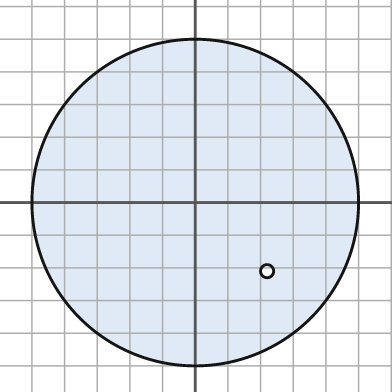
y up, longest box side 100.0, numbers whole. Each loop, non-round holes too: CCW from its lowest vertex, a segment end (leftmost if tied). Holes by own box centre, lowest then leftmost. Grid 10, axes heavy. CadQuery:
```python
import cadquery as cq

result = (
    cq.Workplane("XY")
    .moveTo(0.0, 0.0)
    .circle(50.0)
    .moveTo(22.0, -21.0)
    .circle(2.0)
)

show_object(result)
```